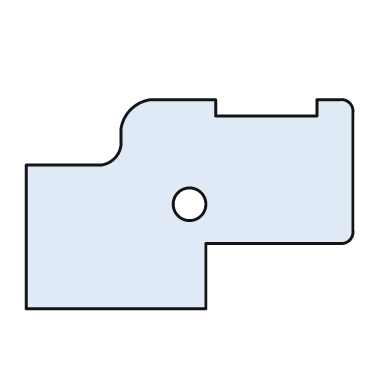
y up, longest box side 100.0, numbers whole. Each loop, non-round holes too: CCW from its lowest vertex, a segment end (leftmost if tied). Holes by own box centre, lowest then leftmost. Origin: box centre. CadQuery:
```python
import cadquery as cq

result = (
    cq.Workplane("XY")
    .moveTo(-50.0, -32.0)
    .lineTo(5.0, -32.0)
    .lineTo(5.0, -12.0)
    .lineTo(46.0, -12.0)
    .threePointArc((49.0, -11.0), (50.0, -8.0))
    .lineTo(50.0, 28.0)
    .threePointArc((49.0, 31.0), (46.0, 32.0))
    .lineTo(39.0, 32.0)
    .lineTo(39.0, 27.0)
    .lineTo(8.0, 27.0)
    .lineTo(8.0, 32.0)
    .lineTo(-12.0, 32.0)
    .threePointArc((-18.0, 29.0), (-21.0, 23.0))
    .lineTo(-21.0, 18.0)
    .threePointArc((-23.0, 14.0), (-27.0, 12.0))
    .lineTo(-50.0, 12.0)
    .close()
    .moveTo(0.0, 0.0)
    .circle(5.0)
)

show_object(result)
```